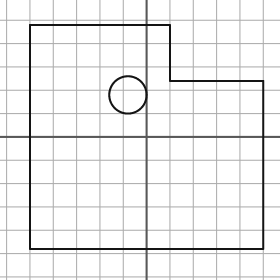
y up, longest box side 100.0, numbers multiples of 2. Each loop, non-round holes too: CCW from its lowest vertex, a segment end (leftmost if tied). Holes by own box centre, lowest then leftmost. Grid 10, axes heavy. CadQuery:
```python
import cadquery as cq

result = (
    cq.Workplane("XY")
    .moveTo(-50.0, -48.0)
    .lineTo(50.0, -48.0)
    .lineTo(50.0, 24.0)
    .lineTo(10.0, 24.0)
    .lineTo(10.0, 48.0)
    .lineTo(-50.0, 48.0)
    .close()
    .moveTo(-8.0, 18.0)
    .circle(8.0)
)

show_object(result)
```